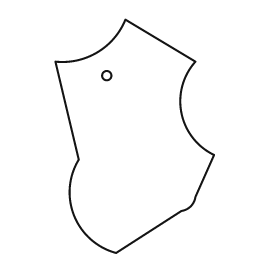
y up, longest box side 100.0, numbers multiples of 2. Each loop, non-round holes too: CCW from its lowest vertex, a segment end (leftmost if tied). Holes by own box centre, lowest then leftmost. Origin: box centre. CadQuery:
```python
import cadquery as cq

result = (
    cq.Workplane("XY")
    .moveTo(-8.0, -50.0)
    .lineTo(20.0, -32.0)
    .threePointArc((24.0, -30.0), (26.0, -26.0))
    .lineTo(34.0, -8.0)
    .threePointArc((20.0, 10.0), (26.0, 32.0))
    .lineTo(-4.0, 50.0)
    .threePointArc((-16.0, 36.0), (-34.0, 32.0))
    .lineTo(-24.0, -10.0)
    .threePointArc((-26.0, -34.0), (-8.0, -50.0))
    .close()
    .moveTo(-12.0, 26.0)
    .circle(2.0)
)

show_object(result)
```